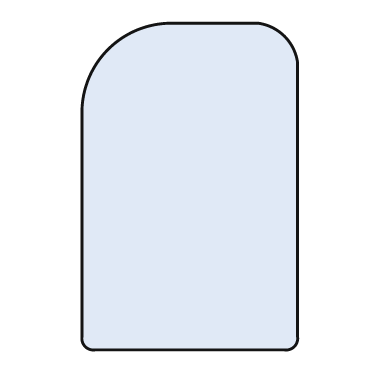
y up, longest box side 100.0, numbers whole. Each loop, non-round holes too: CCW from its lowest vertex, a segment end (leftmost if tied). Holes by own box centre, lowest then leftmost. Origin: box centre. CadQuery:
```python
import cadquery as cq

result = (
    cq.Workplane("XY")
    .moveTo(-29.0, -50.0)
    .lineTo(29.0, -50.0)
    .threePointArc((32.0, -49.0), (33.0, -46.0))
    .lineTo(33.0, 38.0)
    .threePointArc((29.0, 46.0), (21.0, 50.0))
    .lineTo(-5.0, 50.0)
    .threePointArc((-25.0, 42.0), (-33.0, 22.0))
    .lineTo(-33.0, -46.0)
    .threePointArc((-32.0, -49.0), (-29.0, -50.0))
    .close()
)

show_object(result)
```